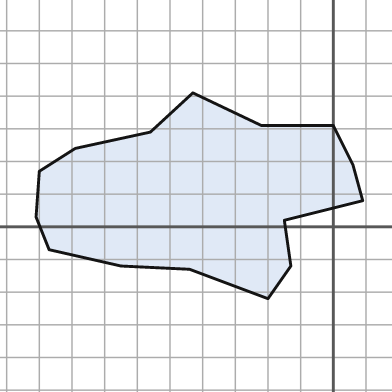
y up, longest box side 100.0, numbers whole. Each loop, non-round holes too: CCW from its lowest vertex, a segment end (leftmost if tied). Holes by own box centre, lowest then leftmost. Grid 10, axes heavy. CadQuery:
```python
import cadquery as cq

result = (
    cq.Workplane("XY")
    .moveTo(-20.0, -22.0)
    .lineTo(-13.0, -12.0)
    .lineTo(-15.0, 2.0)
    .lineTo(9.0, 8.0)
    .lineTo(6.0, 19.0)
    .lineTo(0.0, 31.0)
    .lineTo(-22.0, 31.0)
    .lineTo(-43.0, 41.0)
    .lineTo(-56.0, 29.0)
    .lineTo(-79.0, 24.0)
    .lineTo(-90.0, 17.0)
    .lineTo(-91.0, 3.0)
    .lineTo(-87.0, -7.0)
    .lineTo(-65.0, -12.0)
    .lineTo(-44.0, -13.0)
    .close()
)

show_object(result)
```